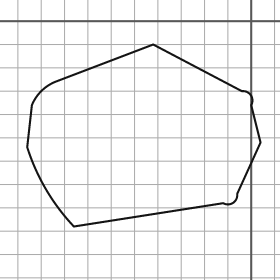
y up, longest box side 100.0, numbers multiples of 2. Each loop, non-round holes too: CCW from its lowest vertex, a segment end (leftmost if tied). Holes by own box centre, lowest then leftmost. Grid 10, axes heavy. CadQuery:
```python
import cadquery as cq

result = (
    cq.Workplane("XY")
    .moveTo(-76.0, -88.0)
    .lineTo(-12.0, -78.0)
    .threePointArc((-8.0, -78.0), (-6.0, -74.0))
    .lineTo(4.0, -52.0)
    .lineTo(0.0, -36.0)
    .threePointArc((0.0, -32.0), (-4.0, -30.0))
    .lineTo(-42.0, -10.0)
    .lineTo(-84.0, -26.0)
    .threePointArc((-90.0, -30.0), (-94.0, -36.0))
    .lineTo(-96.0, -54.0)
    .threePointArc((-88.0, -72.0), (-76.0, -88.0))
    .close()
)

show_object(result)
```